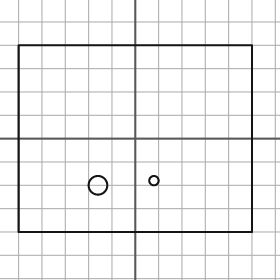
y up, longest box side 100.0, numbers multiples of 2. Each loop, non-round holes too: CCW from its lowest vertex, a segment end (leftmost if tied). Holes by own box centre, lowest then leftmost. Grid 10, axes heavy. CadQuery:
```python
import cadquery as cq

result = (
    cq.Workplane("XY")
    .moveTo(-50.0, -40.0)
    .lineTo(50.0, -40.0)
    .lineTo(50.0, 40.0)
    .lineTo(-50.0, 40.0)
    .close()
    .moveTo(-16.0, -20.0)
    .circle(4.0)
    .moveTo(8.0, -18.0)
    .circle(2.0)
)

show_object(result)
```